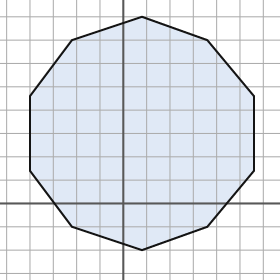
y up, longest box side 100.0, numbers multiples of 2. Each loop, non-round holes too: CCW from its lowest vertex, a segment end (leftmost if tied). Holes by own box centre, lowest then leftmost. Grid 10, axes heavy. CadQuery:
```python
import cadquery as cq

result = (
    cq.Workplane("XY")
    .moveTo(8.0, -20.0)
    .lineTo(36.0, -10.0)
    .lineTo(56.0, 14.0)
    .lineTo(56.0, 46.0)
    .lineTo(36.0, 70.0)
    .lineTo(8.0, 80.0)
    .lineTo(-22.0, 70.0)
    .lineTo(-40.0, 46.0)
    .lineTo(-40.0, 14.0)
    .lineTo(-22.0, -10.0)
    .close()
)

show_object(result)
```